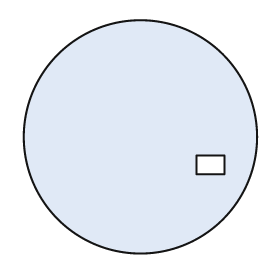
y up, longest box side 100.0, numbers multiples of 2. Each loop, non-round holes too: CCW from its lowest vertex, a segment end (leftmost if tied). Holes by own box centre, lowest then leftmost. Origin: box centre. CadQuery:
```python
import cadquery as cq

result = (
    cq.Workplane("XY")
    .moveTo(0.0, 0.0)
    .circle(50.0)
    .moveTo(24.0, -16.0)
    .lineTo(36.0, -16.0)
    .lineTo(36.0, -8.0)
    .lineTo(24.0, -8.0)
    .close()
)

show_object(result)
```